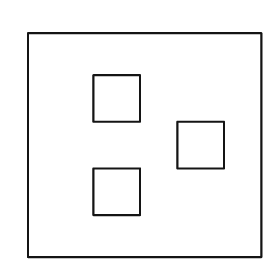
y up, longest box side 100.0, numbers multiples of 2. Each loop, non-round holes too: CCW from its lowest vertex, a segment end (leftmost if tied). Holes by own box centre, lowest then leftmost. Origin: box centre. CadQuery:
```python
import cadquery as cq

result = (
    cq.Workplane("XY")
    .moveTo(-50.0, -48.0)
    .lineTo(50.0, -48.0)
    .lineTo(50.0, 48.0)
    .lineTo(-50.0, 48.0)
    .close()
    .moveTo(-22.0, -30.0)
    .lineTo(-2.0, -30.0)
    .lineTo(-2.0, -10.0)
    .lineTo(-22.0, -10.0)
    .close()
    .moveTo(14.0, -10.0)
    .lineTo(34.0, -10.0)
    .lineTo(34.0, 10.0)
    .lineTo(14.0, 10.0)
    .close()
    .moveTo(-22.0, 10.0)
    .lineTo(-2.0, 10.0)
    .lineTo(-2.0, 30.0)
    .lineTo(-22.0, 30.0)
    .close()
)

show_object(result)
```